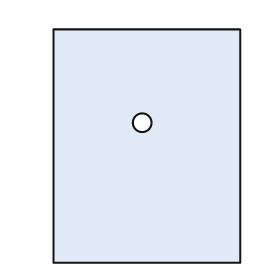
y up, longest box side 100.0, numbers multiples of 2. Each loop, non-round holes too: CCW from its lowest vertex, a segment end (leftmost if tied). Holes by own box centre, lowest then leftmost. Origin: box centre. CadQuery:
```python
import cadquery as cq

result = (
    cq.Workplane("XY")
    .moveTo(-40.0, -50.0)
    .lineTo(40.0, -50.0)
    .lineTo(40.0, 50.0)
    .lineTo(-40.0, 50.0)
    .close()
    .moveTo(-2.0, 10.0)
    .circle(4.0)
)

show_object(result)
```